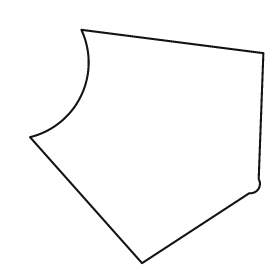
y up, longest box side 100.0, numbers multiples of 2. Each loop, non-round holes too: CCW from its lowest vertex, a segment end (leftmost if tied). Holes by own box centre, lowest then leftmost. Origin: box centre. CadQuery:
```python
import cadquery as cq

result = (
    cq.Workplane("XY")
    .moveTo(-2.0, -50.0)
    .lineTo(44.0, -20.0)
    .threePointArc((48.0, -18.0), (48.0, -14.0))
    .lineTo(50.0, 40.0)
    .lineTo(-28.0, 50.0)
    .threePointArc((-28.0, 22.0), (-50.0, 4.0))
    .close()
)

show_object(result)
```